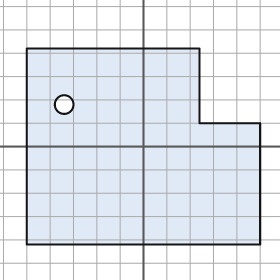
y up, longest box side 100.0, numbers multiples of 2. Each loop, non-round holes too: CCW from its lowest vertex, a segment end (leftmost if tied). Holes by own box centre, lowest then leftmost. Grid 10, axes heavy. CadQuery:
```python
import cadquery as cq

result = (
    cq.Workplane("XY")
    .moveTo(-50.0, -42.0)
    .lineTo(50.0, -42.0)
    .lineTo(50.0, 10.0)
    .lineTo(24.0, 10.0)
    .lineTo(24.0, 42.0)
    .lineTo(-50.0, 42.0)
    .close()
    .moveTo(-34.0, 18.0)
    .circle(4.0)
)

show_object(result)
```